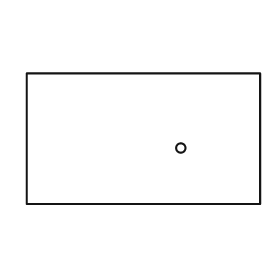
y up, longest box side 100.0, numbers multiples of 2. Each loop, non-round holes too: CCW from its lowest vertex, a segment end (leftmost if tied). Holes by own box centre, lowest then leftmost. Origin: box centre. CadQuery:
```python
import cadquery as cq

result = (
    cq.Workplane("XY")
    .moveTo(-50.0, -28.0)
    .lineTo(50.0, -28.0)
    .lineTo(50.0, 28.0)
    .lineTo(-50.0, 28.0)
    .close()
    .moveTo(16.0, -4.0)
    .circle(2.0)
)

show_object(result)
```